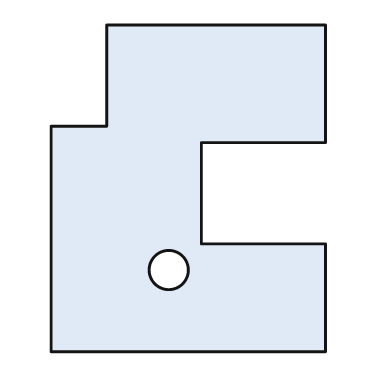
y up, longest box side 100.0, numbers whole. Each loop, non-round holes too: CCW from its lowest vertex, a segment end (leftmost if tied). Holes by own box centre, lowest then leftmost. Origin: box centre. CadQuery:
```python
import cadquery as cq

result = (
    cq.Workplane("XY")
    .moveTo(-42.0, -50.0)
    .lineTo(42.0, -50.0)
    .lineTo(42.0, -17.0)
    .lineTo(4.0, -17.0)
    .lineTo(4.0, 14.0)
    .lineTo(42.0, 14.0)
    .lineTo(42.0, 50.0)
    .lineTo(-25.0, 50.0)
    .lineTo(-25.0, 19.0)
    .lineTo(-42.0, 19.0)
    .close()
    .moveTo(-6.0, -25.0)
    .circle(6.0)
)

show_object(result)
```